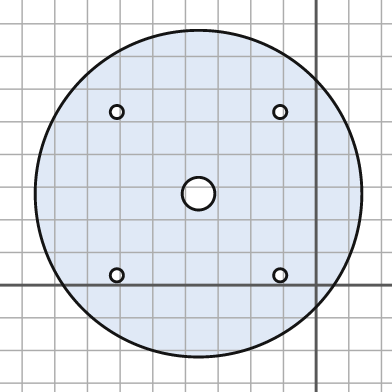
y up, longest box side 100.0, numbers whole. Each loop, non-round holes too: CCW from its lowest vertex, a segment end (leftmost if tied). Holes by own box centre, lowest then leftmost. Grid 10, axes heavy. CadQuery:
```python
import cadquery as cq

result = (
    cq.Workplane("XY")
    .moveTo(-36.0, 28.0)
    .circle(50.0)
    .moveTo(-61.0, 3.0)
    .circle(2.0)
    .moveTo(-11.0, 3.0)
    .circle(2.0)
    .moveTo(-36.0, 28.0)
    .circle(5.0)
    .moveTo(-61.0, 53.0)
    .circle(2.0)
    .moveTo(-11.0, 53.0)
    .circle(2.0)
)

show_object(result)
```